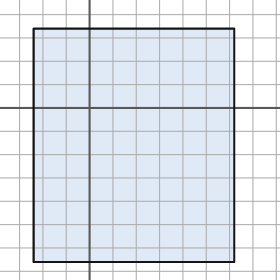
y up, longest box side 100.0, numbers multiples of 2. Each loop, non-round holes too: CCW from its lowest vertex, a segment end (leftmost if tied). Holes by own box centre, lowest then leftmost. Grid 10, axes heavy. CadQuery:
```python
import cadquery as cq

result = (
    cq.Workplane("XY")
    .moveTo(-24.0, -66.0)
    .lineTo(62.0, -66.0)
    .lineTo(62.0, 34.0)
    .lineTo(-24.0, 34.0)
    .close()
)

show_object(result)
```